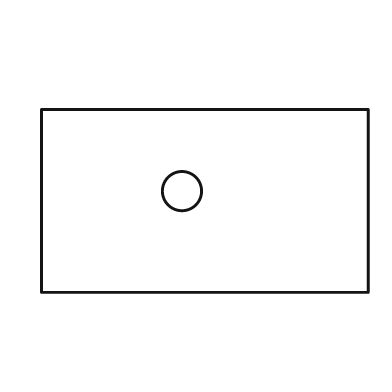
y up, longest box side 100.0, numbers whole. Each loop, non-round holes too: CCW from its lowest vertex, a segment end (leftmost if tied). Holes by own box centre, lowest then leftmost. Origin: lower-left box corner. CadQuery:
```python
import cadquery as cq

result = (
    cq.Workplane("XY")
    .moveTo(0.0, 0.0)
    .lineTo(100.0, 0.0)
    .lineTo(100.0, 56.0)
    .lineTo(0.0, 56.0)
    .close()
    .moveTo(43.0, 31.0)
    .circle(6.0)
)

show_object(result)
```